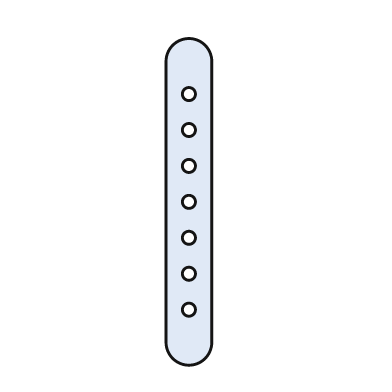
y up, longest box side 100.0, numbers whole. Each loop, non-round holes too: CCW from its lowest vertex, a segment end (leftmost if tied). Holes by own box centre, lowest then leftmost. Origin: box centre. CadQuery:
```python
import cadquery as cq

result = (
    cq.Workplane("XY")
    .moveTo(-7.0, -43.0)
    .threePointArc((0.0, -50.0), (7.0, -43.0))
    .lineTo(7.0, 43.0)
    .threePointArc((0.0, 50.0), (-7.0, 43.0))
    .close()
    .moveTo(0.0, -33.0)
    .circle(2.0)
    .moveTo(0.0, -22.0)
    .circle(2.0)
    .moveTo(0.0, -11.0)
    .circle(2.0)
    .moveTo(0.0, 0.0)
    .circle(2.0)
    .moveTo(0.0, 11.0)
    .circle(2.0)
    .moveTo(0.0, 22.0)
    .circle(2.0)
    .moveTo(0.0, 33.0)
    .circle(2.0)
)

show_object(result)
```